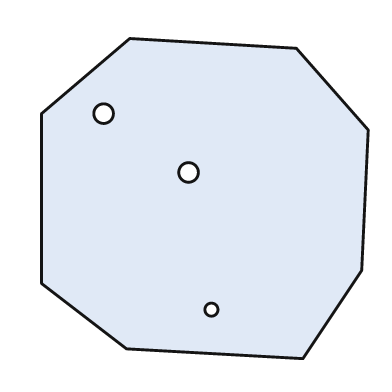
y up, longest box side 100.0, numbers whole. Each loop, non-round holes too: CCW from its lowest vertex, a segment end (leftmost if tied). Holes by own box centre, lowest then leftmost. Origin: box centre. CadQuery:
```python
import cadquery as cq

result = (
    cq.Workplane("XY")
    .moveTo(30.0, -49.0)
    .lineTo(48.0, -22.0)
    .lineTo(50.0, 21.0)
    .lineTo(28.0, 46.0)
    .lineTo(-23.0, 49.0)
    .lineTo(-50.0, 26.0)
    .lineTo(-50.0, -26.0)
    .lineTo(-24.0, -46.0)
    .close()
    .moveTo(2.0, -34.0)
    .circle(2.0)
    .moveTo(-5.0, 8.0)
    .circle(3.0)
    .moveTo(-31.0, 26.0)
    .circle(3.0)
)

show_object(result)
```